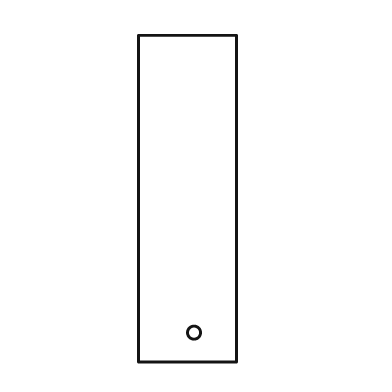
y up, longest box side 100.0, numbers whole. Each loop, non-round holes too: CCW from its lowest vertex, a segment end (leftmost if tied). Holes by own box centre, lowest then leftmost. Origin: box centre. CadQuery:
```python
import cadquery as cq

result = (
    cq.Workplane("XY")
    .moveTo(-15.0, -50.0)
    .lineTo(15.0, -50.0)
    .lineTo(15.0, 50.0)
    .lineTo(-15.0, 50.0)
    .close()
    .moveTo(2.0, -41.0)
    .circle(2.0)
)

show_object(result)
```